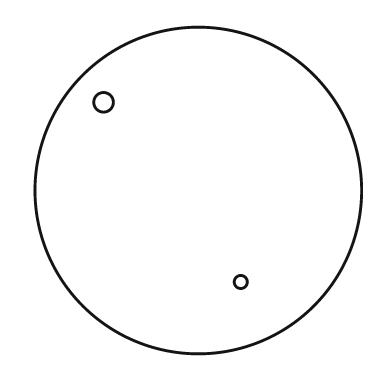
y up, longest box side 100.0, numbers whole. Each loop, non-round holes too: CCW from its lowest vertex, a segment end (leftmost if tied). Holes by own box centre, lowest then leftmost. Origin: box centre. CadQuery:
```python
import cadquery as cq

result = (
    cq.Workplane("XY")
    .moveTo(0.0, 0.0)
    .circle(50.0)
    .moveTo(13.0, -28.0)
    .circle(2.0)
    .moveTo(-29.0, 27.0)
    .circle(3.0)
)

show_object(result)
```